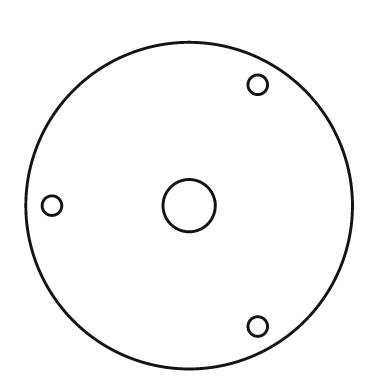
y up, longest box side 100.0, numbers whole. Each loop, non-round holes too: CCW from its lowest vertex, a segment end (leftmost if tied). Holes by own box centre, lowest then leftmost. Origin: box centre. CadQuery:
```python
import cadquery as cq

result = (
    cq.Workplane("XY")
    .moveTo(0.0, 0.0)
    .circle(50.0)
    .moveTo(21.0, -37.0)
    .circle(3.0)
    .moveTo(-42.0, 0.0)
    .circle(3.0)
    .moveTo(0.0, 0.0)
    .circle(8.0)
    .moveTo(21.0, 37.0)
    .circle(3.0)
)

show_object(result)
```